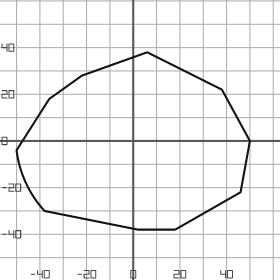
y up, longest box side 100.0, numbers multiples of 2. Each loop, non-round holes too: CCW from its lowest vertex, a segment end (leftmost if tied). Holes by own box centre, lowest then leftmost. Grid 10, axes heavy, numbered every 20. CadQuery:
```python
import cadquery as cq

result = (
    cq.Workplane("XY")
    .moveTo(2.0, -38.0)
    .lineTo(18.0, -38.0)
    .lineTo(46.0, -22.0)
    .lineTo(50.0, 0.0)
    .lineTo(38.0, 22.0)
    .lineTo(6.0, 38.0)
    .lineTo(-22.0, 28.0)
    .lineTo(-36.0, 18.0)
    .lineTo(-50.0, -4.0)
    .threePointArc((-46.0, -18.0), (-38.0, -30.0))
    .close()
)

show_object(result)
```